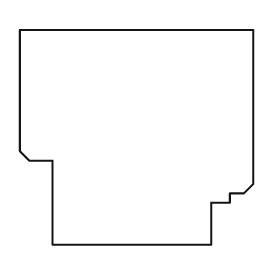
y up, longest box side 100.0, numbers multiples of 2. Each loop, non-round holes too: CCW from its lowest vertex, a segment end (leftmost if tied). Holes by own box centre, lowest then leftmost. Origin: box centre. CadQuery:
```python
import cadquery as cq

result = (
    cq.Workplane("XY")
    .moveTo(-36.0, -46.0)
    .lineTo(32.0, -46.0)
    .lineTo(32.0, -28.0)
    .lineTo(40.0, -28.0)
    .lineTo(40.0, -24.0)
    .lineTo(46.0, -24.0)
    .lineTo(50.0, -20.0)
    .lineTo(50.0, 46.0)
    .lineTo(-50.0, 46.0)
    .lineTo(-50.0, -6.0)
    .lineTo(-46.0, -10.0)
    .lineTo(-36.0, -10.0)
    .close()
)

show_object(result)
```